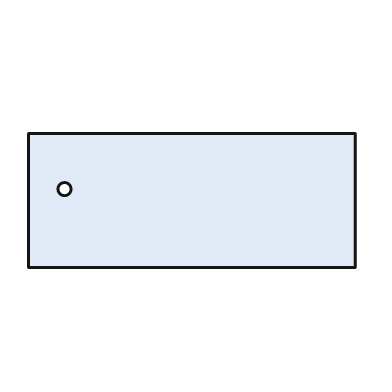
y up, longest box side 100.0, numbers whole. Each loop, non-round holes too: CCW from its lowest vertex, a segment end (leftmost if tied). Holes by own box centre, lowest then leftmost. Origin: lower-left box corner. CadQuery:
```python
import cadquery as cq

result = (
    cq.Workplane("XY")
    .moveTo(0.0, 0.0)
    .lineTo(100.0, 0.0)
    .lineTo(100.0, 41.0)
    .lineTo(0.0, 41.0)
    .close()
    .moveTo(11.0, 24.0)
    .circle(2.0)
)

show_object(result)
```